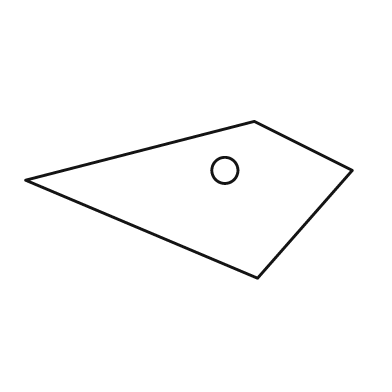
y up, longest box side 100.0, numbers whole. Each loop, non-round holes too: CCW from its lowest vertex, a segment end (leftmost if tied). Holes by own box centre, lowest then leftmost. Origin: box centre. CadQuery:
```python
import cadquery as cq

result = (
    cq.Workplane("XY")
    .moveTo(21.0, -24.0)
    .lineTo(50.0, 9.0)
    .lineTo(20.0, 24.0)
    .lineTo(-50.0, 6.0)
    .close()
    .moveTo(11.0, 9.0)
    .circle(4.0)
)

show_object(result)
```